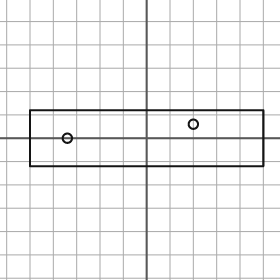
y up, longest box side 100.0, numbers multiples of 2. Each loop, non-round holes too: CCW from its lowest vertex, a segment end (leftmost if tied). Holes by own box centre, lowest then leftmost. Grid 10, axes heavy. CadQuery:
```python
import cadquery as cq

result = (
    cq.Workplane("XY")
    .moveTo(-50.0, -12.0)
    .lineTo(50.0, -12.0)
    .lineTo(50.0, 12.0)
    .lineTo(-50.0, 12.0)
    .close()
    .moveTo(-34.0, 0.0)
    .circle(2.0)
    .moveTo(20.0, 6.0)
    .circle(2.0)
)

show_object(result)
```